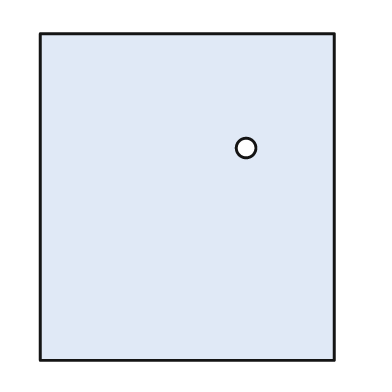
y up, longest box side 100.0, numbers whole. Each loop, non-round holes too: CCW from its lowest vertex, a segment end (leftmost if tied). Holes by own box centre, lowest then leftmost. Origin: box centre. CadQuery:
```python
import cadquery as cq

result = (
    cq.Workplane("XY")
    .moveTo(-45.0, -50.0)
    .lineTo(45.0, -50.0)
    .lineTo(45.0, 50.0)
    .lineTo(-45.0, 50.0)
    .close()
    .moveTo(18.0, 15.0)
    .circle(3.0)
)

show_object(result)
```